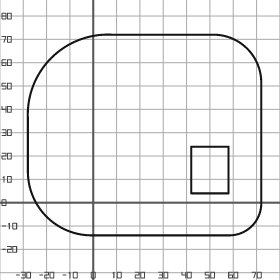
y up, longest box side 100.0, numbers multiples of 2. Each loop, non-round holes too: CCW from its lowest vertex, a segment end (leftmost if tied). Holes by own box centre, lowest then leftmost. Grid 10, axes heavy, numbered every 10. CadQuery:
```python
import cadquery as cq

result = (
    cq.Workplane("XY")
    .moveTo(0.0, -14.0)
    .lineTo(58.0, -14.0)
    .threePointArc((68.0, -10.0), (72.0, 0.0))
    .lineTo(72.0, 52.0)
    .threePointArc((66.0, 66.0), (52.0, 72.0))
    .lineTo(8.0, 72.0)
    .threePointArc((-18.0, 62.0), (-28.0, 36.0))
    .lineTo(-28.0, 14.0)
    .threePointArc((-20.0, -6.0), (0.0, -14.0))
    .close()
    .moveTo(42.0, 4.0)
    .lineTo(58.0, 4.0)
    .lineTo(58.0, 24.0)
    .lineTo(42.0, 24.0)
    .close()
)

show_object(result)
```